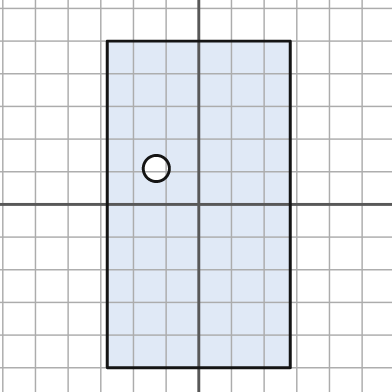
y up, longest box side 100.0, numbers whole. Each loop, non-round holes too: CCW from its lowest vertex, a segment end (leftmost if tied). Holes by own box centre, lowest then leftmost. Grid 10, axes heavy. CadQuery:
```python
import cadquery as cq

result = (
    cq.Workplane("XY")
    .moveTo(-28.0, -50.0)
    .lineTo(28.0, -50.0)
    .lineTo(28.0, 50.0)
    .lineTo(-28.0, 50.0)
    .close()
    .moveTo(-13.0, 11.0)
    .circle(4.0)
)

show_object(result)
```